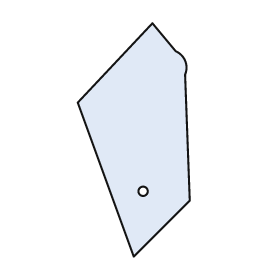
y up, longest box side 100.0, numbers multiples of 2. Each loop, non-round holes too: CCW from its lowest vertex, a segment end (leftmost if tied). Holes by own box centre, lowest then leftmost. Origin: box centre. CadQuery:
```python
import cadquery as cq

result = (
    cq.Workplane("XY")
    .moveTo(0.0, -50.0)
    .lineTo(24.0, -26.0)
    .lineTo(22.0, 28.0)
    .threePointArc((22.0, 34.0), (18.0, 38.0))
    .lineTo(8.0, 50.0)
    .lineTo(-24.0, 16.0)
    .close()
    .moveTo(4.0, -22.0)
    .circle(2.0)
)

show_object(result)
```